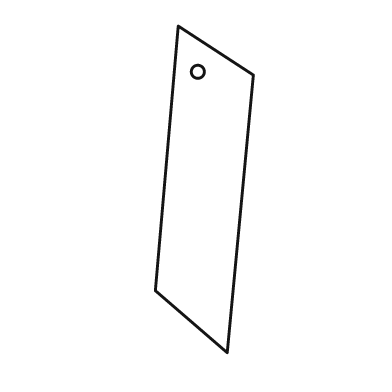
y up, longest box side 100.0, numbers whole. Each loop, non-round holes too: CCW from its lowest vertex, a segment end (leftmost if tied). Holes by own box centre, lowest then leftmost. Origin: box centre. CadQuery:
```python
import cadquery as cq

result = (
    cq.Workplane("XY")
    .moveTo(7.0, -50.0)
    .lineTo(15.0, 35.0)
    .lineTo(-8.0, 50.0)
    .lineTo(-15.0, -31.0)
    .close()
    .moveTo(-2.0, 36.0)
    .circle(2.0)
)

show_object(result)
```